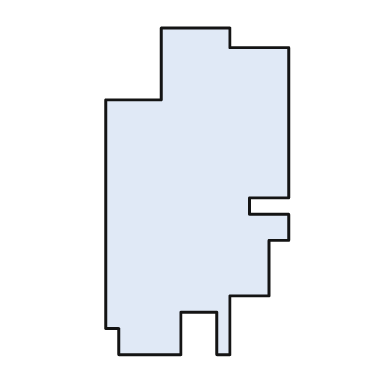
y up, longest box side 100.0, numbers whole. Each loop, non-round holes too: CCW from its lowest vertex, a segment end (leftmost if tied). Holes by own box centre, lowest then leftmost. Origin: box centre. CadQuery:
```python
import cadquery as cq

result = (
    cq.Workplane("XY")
    .moveTo(-24.0, -50.0)
    .lineTo(-5.0, -50.0)
    .lineTo(-5.0, -37.0)
    .lineTo(6.0, -37.0)
    .lineTo(6.0, -50.0)
    .lineTo(10.0, -50.0)
    .lineTo(10.0, -32.0)
    .lineTo(22.0, -32.0)
    .lineTo(22.0, -15.0)
    .lineTo(28.0, -15.0)
    .lineTo(28.0, -7.0)
    .lineTo(16.0, -7.0)
    .lineTo(16.0, -2.0)
    .lineTo(28.0, -2.0)
    .lineTo(28.0, 44.0)
    .lineTo(10.0, 44.0)
    .lineTo(10.0, 50.0)
    .lineTo(-11.0, 50.0)
    .lineTo(-11.0, 28.0)
    .lineTo(-28.0, 28.0)
    .lineTo(-28.0, -42.0)
    .lineTo(-24.0, -42.0)
    .close()
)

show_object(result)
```